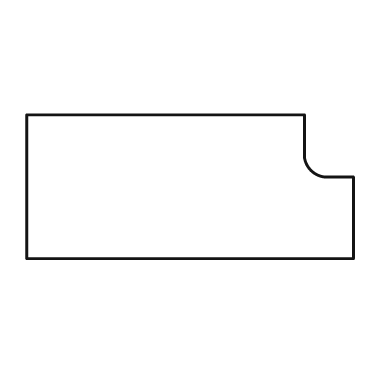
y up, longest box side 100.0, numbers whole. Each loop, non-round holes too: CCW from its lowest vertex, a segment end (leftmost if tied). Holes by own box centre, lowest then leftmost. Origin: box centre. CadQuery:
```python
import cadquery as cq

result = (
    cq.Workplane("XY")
    .moveTo(-50.0, -22.0)
    .lineTo(50.0, -22.0)
    .lineTo(50.0, 3.0)
    .lineTo(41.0, 3.0)
    .threePointArc((37.0, 5.0), (35.0, 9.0))
    .lineTo(35.0, 22.0)
    .lineTo(-50.0, 22.0)
    .close()
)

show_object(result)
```